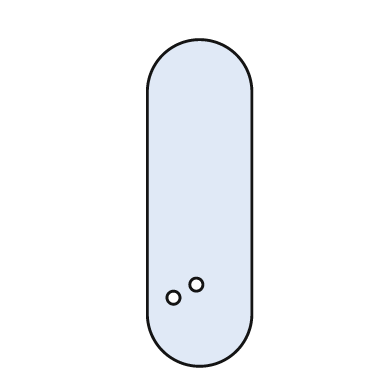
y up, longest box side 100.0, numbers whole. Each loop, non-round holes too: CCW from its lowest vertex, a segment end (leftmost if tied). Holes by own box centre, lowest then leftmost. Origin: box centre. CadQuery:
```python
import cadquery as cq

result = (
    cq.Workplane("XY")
    .moveTo(-16.0, -34.0)
    .threePointArc((0.0, -50.0), (16.0, -34.0))
    .lineTo(16.0, 34.0)
    .threePointArc((0.0, 50.0), (-16.0, 34.0))
    .close()
    .moveTo(-8.0, -29.0)
    .circle(2.0)
    .moveTo(-1.0, -25.0)
    .circle(2.0)
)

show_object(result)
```